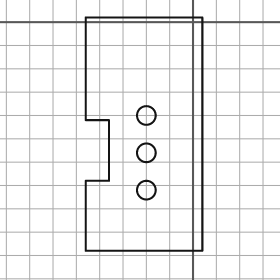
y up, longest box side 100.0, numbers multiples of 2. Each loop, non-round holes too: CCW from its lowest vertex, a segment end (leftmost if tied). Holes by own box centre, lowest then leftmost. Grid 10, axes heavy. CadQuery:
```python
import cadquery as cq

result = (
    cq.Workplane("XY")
    .moveTo(-46.0, -98.0)
    .lineTo(4.0, -98.0)
    .lineTo(4.0, 2.0)
    .lineTo(-46.0, 2.0)
    .lineTo(-46.0, -42.0)
    .lineTo(-36.0, -42.0)
    .lineTo(-36.0, -68.0)
    .lineTo(-46.0, -68.0)
    .close()
    .moveTo(-20.0, -72.0)
    .circle(4.0)
    .moveTo(-20.0, -56.0)
    .circle(4.0)
    .moveTo(-20.0, -40.0)
    .circle(4.0)
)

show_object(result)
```